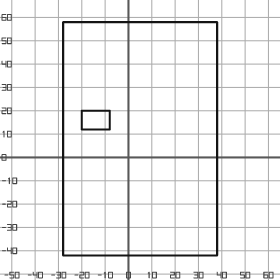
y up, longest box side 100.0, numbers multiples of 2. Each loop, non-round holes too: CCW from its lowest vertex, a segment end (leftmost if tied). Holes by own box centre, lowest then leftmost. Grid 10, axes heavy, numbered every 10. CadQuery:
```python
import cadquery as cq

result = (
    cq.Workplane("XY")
    .moveTo(-28.0, -42.0)
    .lineTo(38.0, -42.0)
    .lineTo(38.0, 58.0)
    .lineTo(-28.0, 58.0)
    .close()
    .moveTo(-20.0, 12.0)
    .lineTo(-8.0, 12.0)
    .lineTo(-8.0, 20.0)
    .lineTo(-20.0, 20.0)
    .close()
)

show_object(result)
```